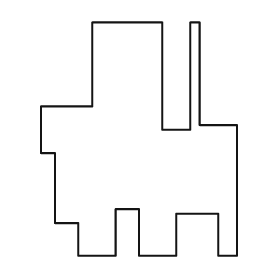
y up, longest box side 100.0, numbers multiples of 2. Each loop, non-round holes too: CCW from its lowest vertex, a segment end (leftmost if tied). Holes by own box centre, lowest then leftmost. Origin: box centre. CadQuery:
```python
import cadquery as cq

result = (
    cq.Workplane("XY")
    .moveTo(-26.0, -50.0)
    .lineTo(-10.0, -50.0)
    .lineTo(-10.0, -30.0)
    .lineTo(0.0, -30.0)
    .lineTo(0.0, -50.0)
    .lineTo(16.0, -50.0)
    .lineTo(16.0, -32.0)
    .lineTo(34.0, -32.0)
    .lineTo(34.0, -50.0)
    .lineTo(42.0, -50.0)
    .lineTo(42.0, 6.0)
    .lineTo(26.0, 6.0)
    .lineTo(26.0, 50.0)
    .lineTo(22.0, 50.0)
    .lineTo(22.0, 4.0)
    .lineTo(10.0, 4.0)
    .lineTo(10.0, 50.0)
    .lineTo(-20.0, 50.0)
    .lineTo(-20.0, 14.0)
    .lineTo(-42.0, 14.0)
    .lineTo(-42.0, -6.0)
    .lineTo(-36.0, -6.0)
    .lineTo(-36.0, -36.0)
    .lineTo(-26.0, -36.0)
    .close()
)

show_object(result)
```